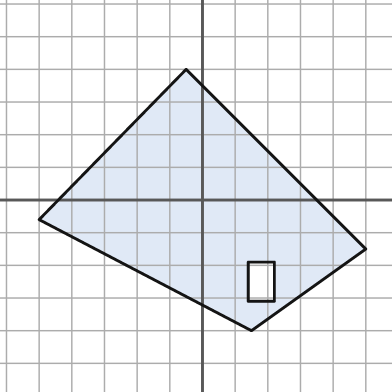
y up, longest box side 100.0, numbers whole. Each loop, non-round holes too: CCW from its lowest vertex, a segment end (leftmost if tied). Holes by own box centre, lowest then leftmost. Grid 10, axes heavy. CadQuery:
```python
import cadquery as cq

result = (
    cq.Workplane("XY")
    .moveTo(15.0, -40.0)
    .lineTo(50.0, -15.0)
    .lineTo(-5.0, 40.0)
    .lineTo(-50.0, -6.0)
    .close()
    .moveTo(14.0, -31.0)
    .lineTo(22.0, -31.0)
    .lineTo(22.0, -19.0)
    .lineTo(14.0, -19.0)
    .close()
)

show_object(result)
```